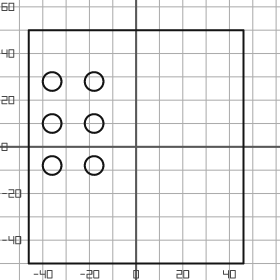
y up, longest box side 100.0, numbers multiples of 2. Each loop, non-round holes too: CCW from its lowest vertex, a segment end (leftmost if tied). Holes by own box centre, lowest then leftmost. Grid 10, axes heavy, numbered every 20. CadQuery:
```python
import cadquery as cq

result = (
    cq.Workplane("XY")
    .moveTo(-46.0, -50.0)
    .lineTo(46.0, -50.0)
    .lineTo(46.0, 50.0)
    .lineTo(-46.0, 50.0)
    .close()
    .moveTo(-36.0, -8.0)
    .circle(4.0)
    .moveTo(-18.0, -8.0)
    .circle(4.0)
    .moveTo(-36.0, 10.0)
    .circle(4.0)
    .moveTo(-18.0, 10.0)
    .circle(4.0)
    .moveTo(-36.0, 28.0)
    .circle(4.0)
    .moveTo(-18.0, 28.0)
    .circle(4.0)
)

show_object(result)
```